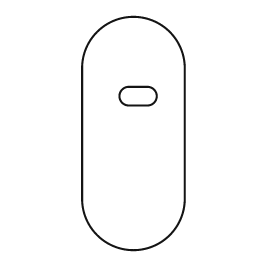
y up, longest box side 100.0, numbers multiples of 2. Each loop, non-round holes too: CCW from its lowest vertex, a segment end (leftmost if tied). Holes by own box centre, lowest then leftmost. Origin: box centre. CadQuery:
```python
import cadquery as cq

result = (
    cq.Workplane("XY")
    .moveTo(-22.0, -28.0)
    .threePointArc((0.0, -50.0), (22.0, -28.0))
    .lineTo(22.0, 28.0)
    .threePointArc((0.0, 50.0), (-22.0, 28.0))
    .close()
    .moveTo(-2.0, 12.0)
    .lineTo(6.0, 12.0)
    .threePointArc((10.0, 16.0), (6.0, 20.0))
    .lineTo(-2.0, 20.0)
    .threePointArc((-6.0, 16.0), (-2.0, 12.0))
    .close()
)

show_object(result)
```